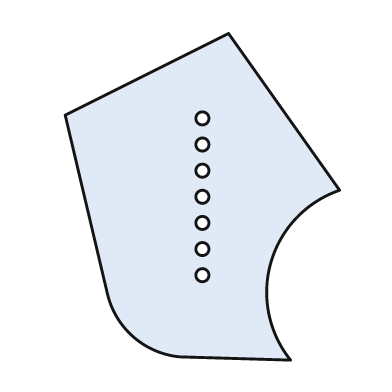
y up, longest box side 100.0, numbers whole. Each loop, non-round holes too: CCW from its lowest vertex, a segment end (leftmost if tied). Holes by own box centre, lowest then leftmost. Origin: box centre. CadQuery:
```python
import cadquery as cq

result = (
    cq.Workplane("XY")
    .moveTo(27.0, -50.0)
    .threePointArc((21.0, -20.0), (42.0, 2.0))
    .lineTo(8.0, 50.0)
    .lineTo(-42.0, 25.0)
    .lineTo(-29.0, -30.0)
    .threePointArc((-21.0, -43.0), (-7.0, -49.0))
    .close()
    .moveTo(0.0, -24.0)
    .circle(2.0)
    .moveTo(0.0, -16.0)
    .circle(2.0)
    .moveTo(0.0, -8.0)
    .circle(2.0)
    .moveTo(0.0, 0.0)
    .circle(2.0)
    .moveTo(0.0, 8.0)
    .circle(2.0)
    .moveTo(0.0, 16.0)
    .circle(2.0)
    .moveTo(0.0, 24.0)
    .circle(2.0)
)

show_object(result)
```